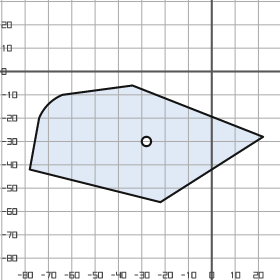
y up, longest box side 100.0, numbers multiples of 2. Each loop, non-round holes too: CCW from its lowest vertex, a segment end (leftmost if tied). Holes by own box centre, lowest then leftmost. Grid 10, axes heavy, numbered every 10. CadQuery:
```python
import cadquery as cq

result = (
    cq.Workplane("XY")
    .moveTo(-22.0, -56.0)
    .lineTo(22.0, -28.0)
    .lineTo(-34.0, -6.0)
    .lineTo(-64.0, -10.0)
    .threePointArc((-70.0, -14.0), (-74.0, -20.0))
    .lineTo(-78.0, -42.0)
    .close()
    .moveTo(-28.0, -30.0)
    .circle(2.0)
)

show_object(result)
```